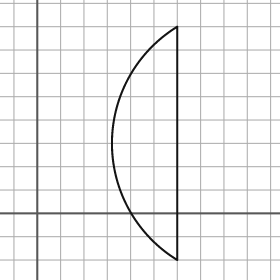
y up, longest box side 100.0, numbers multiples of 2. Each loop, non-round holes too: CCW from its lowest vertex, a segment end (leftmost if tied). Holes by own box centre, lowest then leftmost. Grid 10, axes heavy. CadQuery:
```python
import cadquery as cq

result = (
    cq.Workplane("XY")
    .moveTo(60.0, -20.0)
    .lineTo(60.0, 80.0)
    .threePointArc((32.0, 30.0), (60.0, -20.0))
    .close()
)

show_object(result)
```